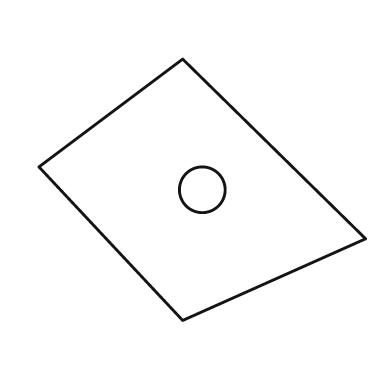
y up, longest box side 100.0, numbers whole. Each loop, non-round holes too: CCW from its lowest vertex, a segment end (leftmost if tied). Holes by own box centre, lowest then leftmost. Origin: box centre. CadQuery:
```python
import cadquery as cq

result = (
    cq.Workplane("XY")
    .moveTo(-6.0, -40.0)
    .lineTo(50.0, -15.0)
    .lineTo(-6.0, 40.0)
    .lineTo(-50.0, 7.0)
    .close()
    .moveTo(0.0, 0.0)
    .circle(7.0)
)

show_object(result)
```